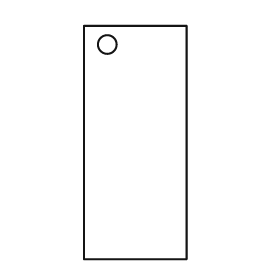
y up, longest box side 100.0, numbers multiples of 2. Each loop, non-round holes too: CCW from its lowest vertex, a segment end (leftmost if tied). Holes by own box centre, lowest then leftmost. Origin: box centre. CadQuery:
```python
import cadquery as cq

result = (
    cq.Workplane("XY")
    .moveTo(-22.0, -50.0)
    .lineTo(22.0, -50.0)
    .lineTo(22.0, 50.0)
    .lineTo(-22.0, 50.0)
    .close()
    .moveTo(-12.0, 42.0)
    .circle(4.0)
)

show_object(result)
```